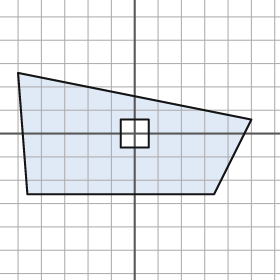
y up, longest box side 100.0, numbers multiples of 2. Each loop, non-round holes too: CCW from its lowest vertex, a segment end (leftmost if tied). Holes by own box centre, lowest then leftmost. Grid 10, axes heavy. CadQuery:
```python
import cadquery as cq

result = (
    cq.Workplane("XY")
    .moveTo(-46.0, -26.0)
    .lineTo(34.0, -26.0)
    .lineTo(50.0, 6.0)
    .lineTo(-50.0, 26.0)
    .close()
    .moveTo(-6.0, -6.0)
    .lineTo(6.0, -6.0)
    .lineTo(6.0, 6.0)
    .lineTo(-6.0, 6.0)
    .close()
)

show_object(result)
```